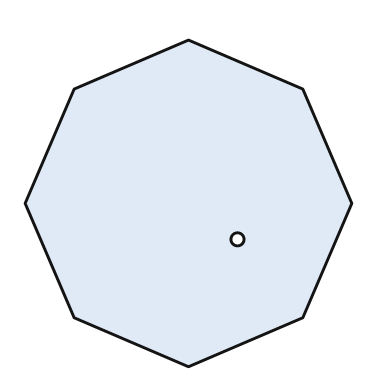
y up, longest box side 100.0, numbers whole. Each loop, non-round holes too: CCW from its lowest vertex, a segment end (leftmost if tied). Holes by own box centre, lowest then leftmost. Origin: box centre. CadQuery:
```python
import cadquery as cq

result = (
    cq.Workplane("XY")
    .moveTo(0.0, -50.0)
    .lineTo(35.0, -35.0)
    .lineTo(50.0, 0.0)
    .lineTo(35.0, 35.0)
    .lineTo(0.0, 50.0)
    .lineTo(-35.0, 35.0)
    .lineTo(-50.0, 0.0)
    .lineTo(-35.0, -35.0)
    .close()
    .moveTo(15.0, -11.0)
    .circle(2.0)
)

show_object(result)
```